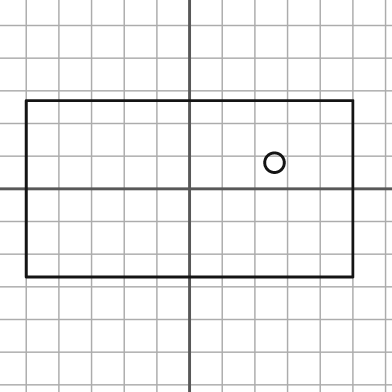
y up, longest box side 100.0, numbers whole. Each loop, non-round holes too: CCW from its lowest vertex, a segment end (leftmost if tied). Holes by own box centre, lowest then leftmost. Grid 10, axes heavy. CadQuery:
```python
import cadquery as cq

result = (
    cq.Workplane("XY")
    .moveTo(-50.0, -27.0)
    .lineTo(50.0, -27.0)
    .lineTo(50.0, 27.0)
    .lineTo(-50.0, 27.0)
    .close()
    .moveTo(26.0, 8.0)
    .circle(3.0)
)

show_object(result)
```